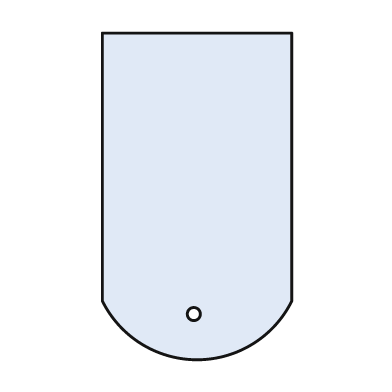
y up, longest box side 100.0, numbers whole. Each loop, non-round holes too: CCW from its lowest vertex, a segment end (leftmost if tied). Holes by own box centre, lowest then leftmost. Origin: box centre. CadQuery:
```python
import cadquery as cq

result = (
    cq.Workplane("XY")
    .moveTo(-29.0, -32.0)
    .threePointArc((0.0, -50.0), (29.0, -32.0))
    .lineTo(29.0, 50.0)
    .lineTo(-29.0, 50.0)
    .close()
    .moveTo(-1.0, -36.0)
    .circle(2.0)
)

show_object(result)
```